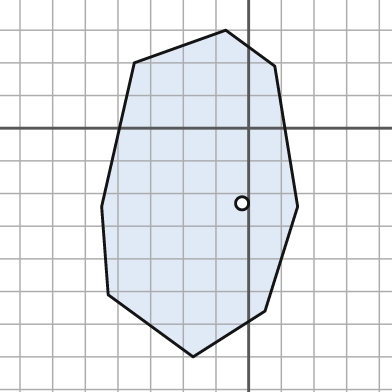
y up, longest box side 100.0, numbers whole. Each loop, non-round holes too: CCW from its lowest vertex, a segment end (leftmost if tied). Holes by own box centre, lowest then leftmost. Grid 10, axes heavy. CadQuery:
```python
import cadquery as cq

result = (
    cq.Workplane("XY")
    .moveTo(-17.0, -70.0)
    .lineTo(5.0, -56.0)
    .lineTo(15.0, -24.0)
    .lineTo(8.0, 19.0)
    .lineTo(-7.0, 30.0)
    .lineTo(-35.0, 20.0)
    .lineTo(-45.0, -24.0)
    .lineTo(-43.0, -51.0)
    .close()
    .moveTo(-2.0, -23.0)
    .circle(2.0)
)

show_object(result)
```